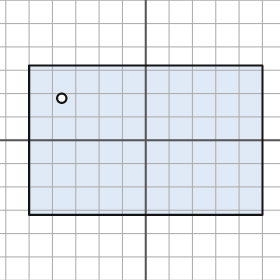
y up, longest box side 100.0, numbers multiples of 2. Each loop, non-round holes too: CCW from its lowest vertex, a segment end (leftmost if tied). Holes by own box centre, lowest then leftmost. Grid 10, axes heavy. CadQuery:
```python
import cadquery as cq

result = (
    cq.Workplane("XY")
    .moveTo(-50.0, -32.0)
    .lineTo(50.0, -32.0)
    .lineTo(50.0, 32.0)
    .lineTo(-50.0, 32.0)
    .close()
    .moveTo(-36.0, 18.0)
    .circle(2.0)
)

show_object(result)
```